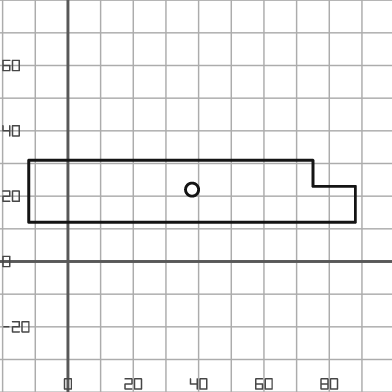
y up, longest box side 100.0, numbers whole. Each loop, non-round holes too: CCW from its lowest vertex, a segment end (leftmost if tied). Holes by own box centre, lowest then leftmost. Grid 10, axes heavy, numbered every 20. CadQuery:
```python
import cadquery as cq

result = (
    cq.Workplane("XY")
    .moveTo(-12.0, 12.0)
    .lineTo(88.0, 12.0)
    .lineTo(88.0, 23.0)
    .lineTo(75.0, 23.0)
    .lineTo(75.0, 31.0)
    .lineTo(-12.0, 31.0)
    .close()
    .moveTo(38.0, 22.0)
    .circle(2.0)
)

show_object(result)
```